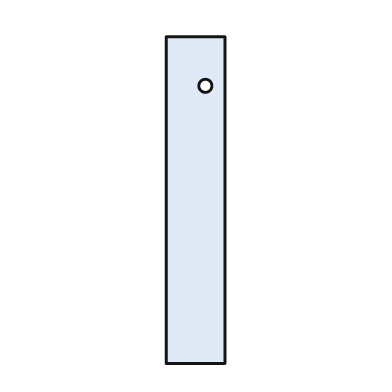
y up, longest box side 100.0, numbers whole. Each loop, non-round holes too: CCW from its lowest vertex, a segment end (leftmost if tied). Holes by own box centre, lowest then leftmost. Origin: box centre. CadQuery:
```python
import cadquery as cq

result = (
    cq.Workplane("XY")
    .moveTo(-9.0, -50.0)
    .lineTo(9.0, -50.0)
    .lineTo(9.0, 50.0)
    .lineTo(-9.0, 50.0)
    .close()
    .moveTo(3.0, 35.0)
    .circle(2.0)
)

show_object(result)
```